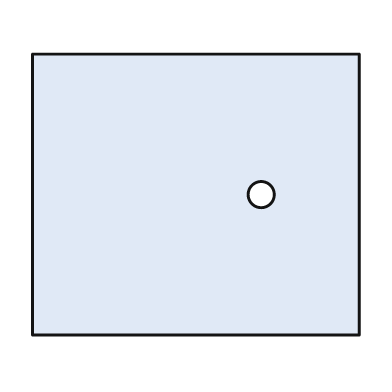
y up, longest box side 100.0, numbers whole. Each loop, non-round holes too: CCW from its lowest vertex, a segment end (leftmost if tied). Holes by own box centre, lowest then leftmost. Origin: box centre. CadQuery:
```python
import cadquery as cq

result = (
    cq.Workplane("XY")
    .moveTo(-50.0, -43.0)
    .lineTo(50.0, -43.0)
    .lineTo(50.0, 43.0)
    .lineTo(-50.0, 43.0)
    .close()
    .moveTo(20.0, 0.0)
    .circle(4.0)
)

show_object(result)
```